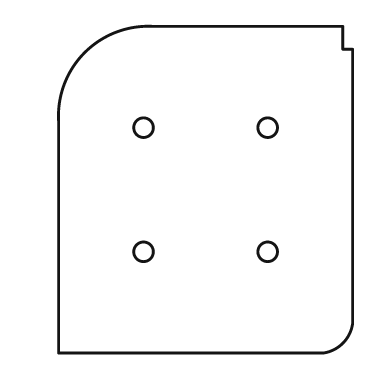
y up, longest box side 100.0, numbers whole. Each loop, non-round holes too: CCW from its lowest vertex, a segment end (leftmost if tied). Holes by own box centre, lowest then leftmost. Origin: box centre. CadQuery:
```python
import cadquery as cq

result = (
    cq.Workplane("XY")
    .moveTo(-45.0, -50.0)
    .lineTo(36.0, -50.0)
    .threePointArc((42.0, -47.0), (45.0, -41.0))
    .lineTo(45.0, 43.0)
    .lineTo(42.0, 43.0)
    .lineTo(42.0, 50.0)
    .lineTo(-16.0, 50.0)
    .threePointArc((-37.0, 42.0), (-45.0, 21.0))
    .close()
    .moveTo(-19.0, -19.0)
    .circle(3.0)
    .moveTo(19.0, -19.0)
    .circle(3.0)
    .moveTo(-19.0, 19.0)
    .circle(3.0)
    .moveTo(19.0, 19.0)
    .circle(3.0)
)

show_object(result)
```